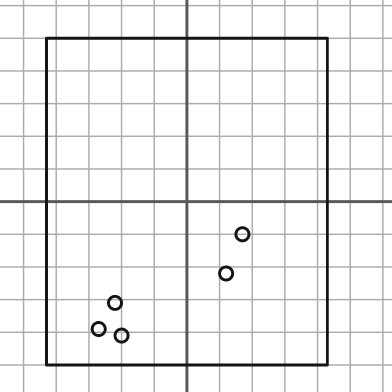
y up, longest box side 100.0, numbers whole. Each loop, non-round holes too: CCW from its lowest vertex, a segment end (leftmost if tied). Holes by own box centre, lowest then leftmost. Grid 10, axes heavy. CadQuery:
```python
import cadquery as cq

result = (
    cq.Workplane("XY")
    .moveTo(-43.0, -50.0)
    .lineTo(43.0, -50.0)
    .lineTo(43.0, 50.0)
    .lineTo(-43.0, 50.0)
    .close()
    .moveTo(-20.0, -41.0)
    .circle(2.0)
    .moveTo(-27.0, -39.0)
    .circle(2.0)
    .moveTo(-22.0, -31.0)
    .circle(2.0)
    .moveTo(12.0, -22.0)
    .circle(2.0)
    .moveTo(17.0, -10.0)
    .circle(2.0)
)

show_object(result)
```